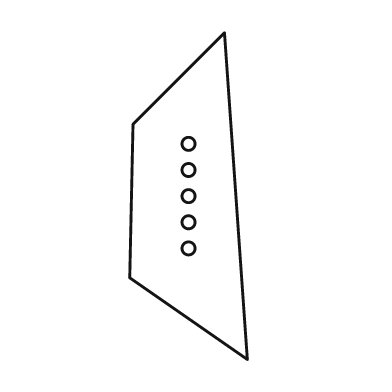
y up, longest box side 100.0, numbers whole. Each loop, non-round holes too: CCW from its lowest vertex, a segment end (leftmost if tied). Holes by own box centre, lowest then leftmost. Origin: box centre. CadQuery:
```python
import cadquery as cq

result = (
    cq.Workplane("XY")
    .moveTo(18.0, -50.0)
    .lineTo(11.0, 50.0)
    .lineTo(-17.0, 22.0)
    .lineTo(-18.0, -25.0)
    .close()
    .moveTo(0.0, -16.0)
    .circle(2.0)
    .moveTo(0.0, -8.0)
    .circle(2.0)
    .moveTo(0.0, 0.0)
    .circle(2.0)
    .moveTo(0.0, 8.0)
    .circle(2.0)
    .moveTo(0.0, 16.0)
    .circle(2.0)
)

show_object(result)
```